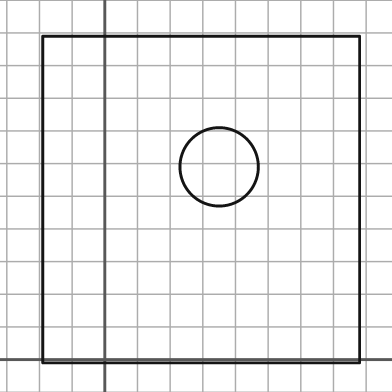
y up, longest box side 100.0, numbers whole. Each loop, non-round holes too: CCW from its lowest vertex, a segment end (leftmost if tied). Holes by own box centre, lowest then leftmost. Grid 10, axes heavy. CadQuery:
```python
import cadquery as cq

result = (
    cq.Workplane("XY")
    .moveTo(-19.0, -1.0)
    .lineTo(78.0, -1.0)
    .lineTo(78.0, 99.0)
    .lineTo(-19.0, 99.0)
    .close()
    .moveTo(35.0, 59.0)
    .circle(12.0)
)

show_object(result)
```